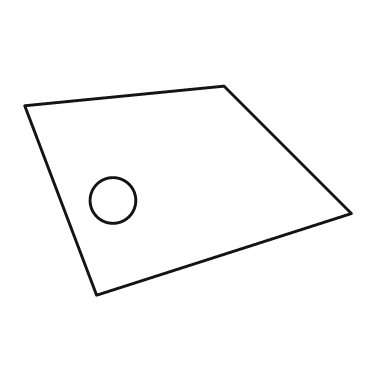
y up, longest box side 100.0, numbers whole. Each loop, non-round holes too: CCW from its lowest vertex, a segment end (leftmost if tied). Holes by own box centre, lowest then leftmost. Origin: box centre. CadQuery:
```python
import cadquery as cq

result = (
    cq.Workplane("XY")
    .moveTo(-28.0, -32.0)
    .lineTo(50.0, -7.0)
    .lineTo(11.0, 32.0)
    .lineTo(-50.0, 26.0)
    .close()
    .moveTo(-23.0, -3.0)
    .circle(7.0)
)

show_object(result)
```